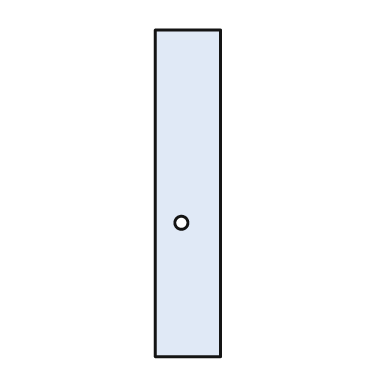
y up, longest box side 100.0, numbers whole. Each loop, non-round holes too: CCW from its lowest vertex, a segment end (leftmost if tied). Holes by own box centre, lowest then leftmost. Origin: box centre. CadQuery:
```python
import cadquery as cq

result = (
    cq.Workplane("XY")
    .moveTo(-10.0, -50.0)
    .lineTo(10.0, -50.0)
    .lineTo(10.0, 50.0)
    .lineTo(-10.0, 50.0)
    .close()
    .moveTo(-2.0, -9.0)
    .circle(2.0)
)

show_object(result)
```